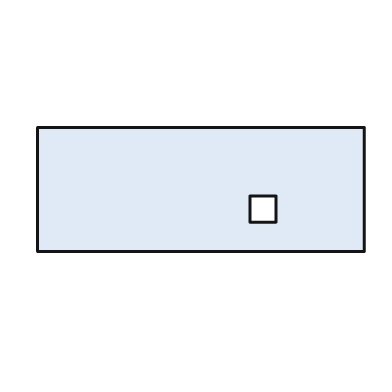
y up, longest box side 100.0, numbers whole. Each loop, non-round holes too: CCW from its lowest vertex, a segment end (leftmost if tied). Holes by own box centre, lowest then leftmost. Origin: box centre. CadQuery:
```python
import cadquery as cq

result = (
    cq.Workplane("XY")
    .moveTo(-50.0, -19.0)
    .lineTo(50.0, -19.0)
    .lineTo(50.0, 19.0)
    .lineTo(-50.0, 19.0)
    .close()
    .moveTo(15.0, -10.0)
    .lineTo(23.0, -10.0)
    .lineTo(23.0, -2.0)
    .lineTo(15.0, -2.0)
    .close()
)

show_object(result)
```